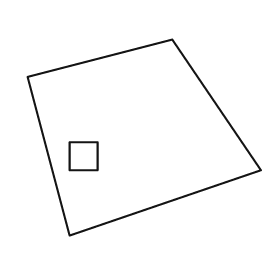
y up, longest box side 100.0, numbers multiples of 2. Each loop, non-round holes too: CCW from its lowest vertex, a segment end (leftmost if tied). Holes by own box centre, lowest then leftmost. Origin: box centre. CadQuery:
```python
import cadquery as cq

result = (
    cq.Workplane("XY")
    .moveTo(-32.0, -42.0)
    .lineTo(50.0, -14.0)
    .lineTo(12.0, 42.0)
    .lineTo(-50.0, 26.0)
    .close()
    .moveTo(-32.0, -14.0)
    .lineTo(-20.0, -14.0)
    .lineTo(-20.0, -2.0)
    .lineTo(-32.0, -2.0)
    .close()
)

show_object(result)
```